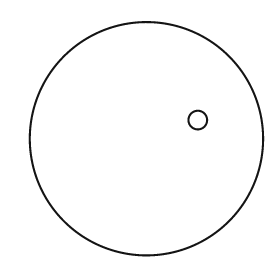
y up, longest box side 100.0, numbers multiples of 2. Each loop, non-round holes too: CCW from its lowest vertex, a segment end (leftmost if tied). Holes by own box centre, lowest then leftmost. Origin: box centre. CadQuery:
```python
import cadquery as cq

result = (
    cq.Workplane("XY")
    .moveTo(0.0, 0.0)
    .circle(50.0)
    .moveTo(22.0, 8.0)
    .circle(4.0)
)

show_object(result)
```